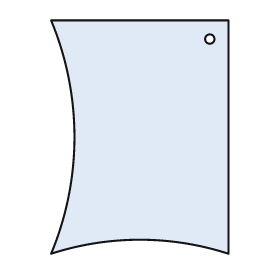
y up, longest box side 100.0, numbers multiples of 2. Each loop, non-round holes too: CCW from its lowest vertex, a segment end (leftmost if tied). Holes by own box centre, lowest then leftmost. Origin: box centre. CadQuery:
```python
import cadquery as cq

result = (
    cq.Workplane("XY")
    .moveTo(-38.0, -50.0)
    .threePointArc((0.0, -44.0), (38.0, -50.0))
    .lineTo(38.0, 50.0)
    .lineTo(-38.0, 50.0)
    .threePointArc((-28.0, 0.0), (-38.0, -50.0))
    .close()
    .moveTo(30.0, 42.0)
    .circle(2.0)
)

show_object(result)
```